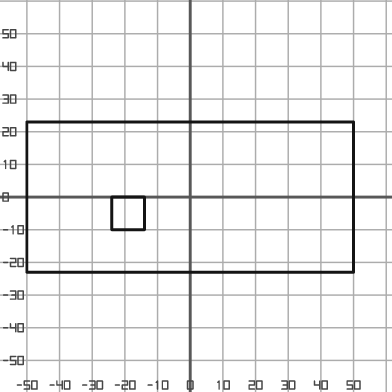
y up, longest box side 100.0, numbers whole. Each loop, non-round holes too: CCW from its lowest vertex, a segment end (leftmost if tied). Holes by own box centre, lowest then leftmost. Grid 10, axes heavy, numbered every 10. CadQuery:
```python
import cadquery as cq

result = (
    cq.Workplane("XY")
    .moveTo(-50.0, -23.0)
    .lineTo(50.0, -23.0)
    .lineTo(50.0, 23.0)
    .lineTo(-50.0, 23.0)
    .close()
    .moveTo(-24.0, -10.0)
    .lineTo(-14.0, -10.0)
    .lineTo(-14.0, 0.0)
    .lineTo(-24.0, 0.0)
    .close()
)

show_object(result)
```